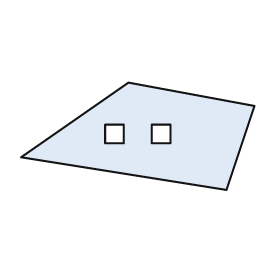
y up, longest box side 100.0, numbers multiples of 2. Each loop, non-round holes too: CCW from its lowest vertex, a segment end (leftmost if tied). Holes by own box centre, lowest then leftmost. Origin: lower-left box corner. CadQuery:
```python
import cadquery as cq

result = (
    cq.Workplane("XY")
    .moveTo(88.0, 0.0)
    .lineTo(100.0, 36.0)
    .lineTo(46.0, 46.0)
    .lineTo(0.0, 14.0)
    .close()
    .moveTo(36.0, 20.0)
    .lineTo(44.0, 20.0)
    .lineTo(44.0, 28.0)
    .lineTo(36.0, 28.0)
    .close()
    .moveTo(56.0, 20.0)
    .lineTo(64.0, 20.0)
    .lineTo(64.0, 28.0)
    .lineTo(56.0, 28.0)
    .close()
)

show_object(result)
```